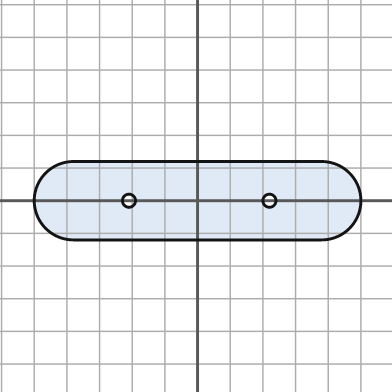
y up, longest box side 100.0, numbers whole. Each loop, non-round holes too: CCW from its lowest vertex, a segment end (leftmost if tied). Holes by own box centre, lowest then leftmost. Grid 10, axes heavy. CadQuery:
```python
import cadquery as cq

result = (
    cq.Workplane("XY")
    .moveTo(-38.0, -12.0)
    .lineTo(38.0, -12.0)
    .threePointArc((50.0, 0.0), (38.0, 12.0))
    .lineTo(-38.0, 12.0)
    .threePointArc((-50.0, 0.0), (-38.0, -12.0))
    .close()
    .moveTo(-21.0, 0.0)
    .circle(2.0)
    .moveTo(22.0, 0.0)
    .circle(2.0)
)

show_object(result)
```